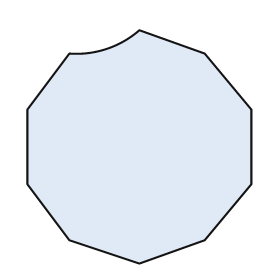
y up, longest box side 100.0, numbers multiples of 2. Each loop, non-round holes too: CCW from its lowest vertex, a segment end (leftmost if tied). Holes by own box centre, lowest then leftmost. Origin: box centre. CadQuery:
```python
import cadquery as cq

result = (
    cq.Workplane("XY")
    .moveTo(0.0, -50.0)
    .lineTo(28.0, -40.0)
    .lineTo(48.0, -16.0)
    .lineTo(48.0, 16.0)
    .lineTo(28.0, 40.0)
    .lineTo(0.0, 50.0)
    .threePointArc((-14.0, 42.0), (-30.0, 40.0))
    .lineTo(-48.0, 16.0)
    .lineTo(-48.0, -16.0)
    .lineTo(-30.0, -40.0)
    .close()
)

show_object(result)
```